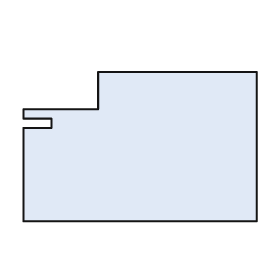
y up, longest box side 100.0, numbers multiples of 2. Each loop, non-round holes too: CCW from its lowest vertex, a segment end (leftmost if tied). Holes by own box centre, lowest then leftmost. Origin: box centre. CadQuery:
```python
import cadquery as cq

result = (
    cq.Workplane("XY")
    .moveTo(-50.0, -32.0)
    .lineTo(50.0, -32.0)
    .lineTo(50.0, 32.0)
    .lineTo(-18.0, 32.0)
    .lineTo(-18.0, 16.0)
    .lineTo(-50.0, 16.0)
    .lineTo(-50.0, 12.0)
    .lineTo(-38.0, 12.0)
    .lineTo(-38.0, 8.0)
    .lineTo(-50.0, 8.0)
    .close()
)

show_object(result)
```